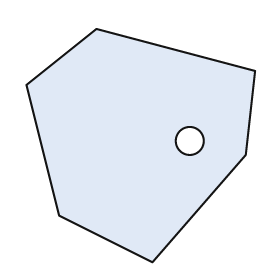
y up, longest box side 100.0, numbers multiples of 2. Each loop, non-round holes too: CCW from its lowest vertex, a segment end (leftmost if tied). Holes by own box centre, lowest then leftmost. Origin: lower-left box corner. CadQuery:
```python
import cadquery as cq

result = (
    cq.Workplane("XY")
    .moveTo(54.0, 0.0)
    .lineTo(94.0, 46.0)
    .lineTo(98.0, 82.0)
    .lineTo(30.0, 100.0)
    .lineTo(0.0, 76.0)
    .lineTo(14.0, 20.0)
    .close()
    .moveTo(70.0, 52.0)
    .circle(6.0)
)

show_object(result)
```